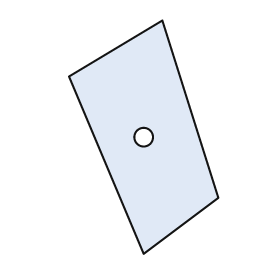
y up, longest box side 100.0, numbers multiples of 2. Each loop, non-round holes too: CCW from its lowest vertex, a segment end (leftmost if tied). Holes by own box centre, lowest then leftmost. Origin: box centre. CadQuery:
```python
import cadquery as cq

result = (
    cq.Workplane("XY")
    .moveTo(0.0, -50.0)
    .lineTo(32.0, -26.0)
    .lineTo(8.0, 50.0)
    .lineTo(-32.0, 26.0)
    .close()
    .moveTo(0.0, 0.0)
    .circle(4.0)
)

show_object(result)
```